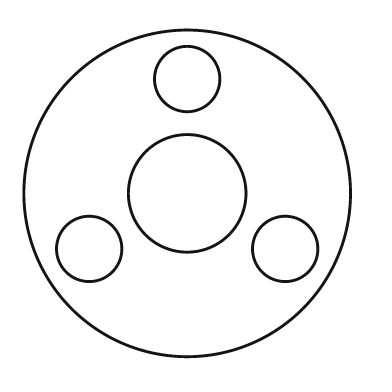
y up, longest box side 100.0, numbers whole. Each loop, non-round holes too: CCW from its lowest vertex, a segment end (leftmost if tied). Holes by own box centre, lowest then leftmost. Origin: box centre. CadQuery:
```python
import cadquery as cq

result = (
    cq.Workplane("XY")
    .moveTo(0.0, 0.0)
    .circle(50.0)
    .moveTo(-30.0, -17.0)
    .circle(10.0)
    .moveTo(30.0, -17.0)
    .circle(10.0)
    .moveTo(0.0, 0.0)
    .circle(18.0)
    .moveTo(0.0, 35.0)
    .circle(10.0)
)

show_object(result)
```